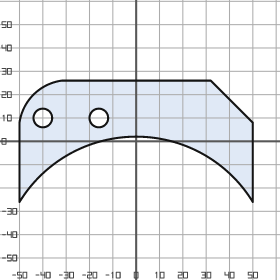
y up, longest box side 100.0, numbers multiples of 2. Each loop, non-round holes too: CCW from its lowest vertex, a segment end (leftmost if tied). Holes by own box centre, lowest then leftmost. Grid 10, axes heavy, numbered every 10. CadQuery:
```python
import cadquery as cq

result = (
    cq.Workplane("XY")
    .moveTo(-50.0, -26.0)
    .threePointArc((0.0, 2.0), (50.0, -26.0))
    .lineTo(50.0, 8.0)
    .lineTo(32.0, 26.0)
    .lineTo(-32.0, 26.0)
    .threePointArc((-44.0, 20.0), (-50.0, 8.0))
    .close()
    .moveTo(-40.0, 10.0)
    .circle(4.0)
    .moveTo(-16.0, 10.0)
    .circle(4.0)
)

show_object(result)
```